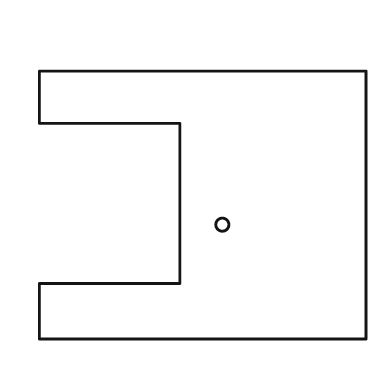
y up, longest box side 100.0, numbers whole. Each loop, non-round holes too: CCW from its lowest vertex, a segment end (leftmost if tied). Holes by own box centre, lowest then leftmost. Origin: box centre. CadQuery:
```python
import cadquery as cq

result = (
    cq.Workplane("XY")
    .moveTo(-50.0, -41.0)
    .lineTo(50.0, -41.0)
    .lineTo(50.0, 41.0)
    .lineTo(-50.0, 41.0)
    .lineTo(-50.0, 25.0)
    .lineTo(-7.0, 25.0)
    .lineTo(-7.0, -24.0)
    .lineTo(-50.0, -24.0)
    .close()
    .moveTo(6.0, -6.0)
    .circle(2.0)
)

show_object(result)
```